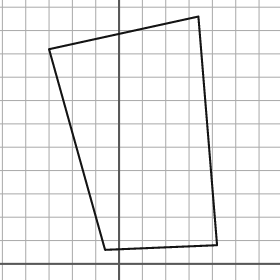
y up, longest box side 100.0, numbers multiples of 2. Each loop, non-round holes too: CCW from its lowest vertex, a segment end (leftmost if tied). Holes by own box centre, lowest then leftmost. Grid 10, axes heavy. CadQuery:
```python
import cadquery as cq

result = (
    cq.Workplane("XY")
    .moveTo(-6.0, 6.0)
    .lineTo(42.0, 8.0)
    .lineTo(34.0, 106.0)
    .lineTo(-30.0, 92.0)
    .close()
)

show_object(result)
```